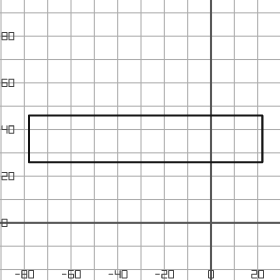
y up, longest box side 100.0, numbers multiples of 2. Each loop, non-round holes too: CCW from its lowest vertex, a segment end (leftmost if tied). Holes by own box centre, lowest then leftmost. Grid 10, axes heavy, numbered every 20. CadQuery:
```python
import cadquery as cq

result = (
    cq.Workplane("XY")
    .moveTo(-78.0, 26.0)
    .lineTo(22.0, 26.0)
    .lineTo(22.0, 46.0)
    .lineTo(-78.0, 46.0)
    .close()
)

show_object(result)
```